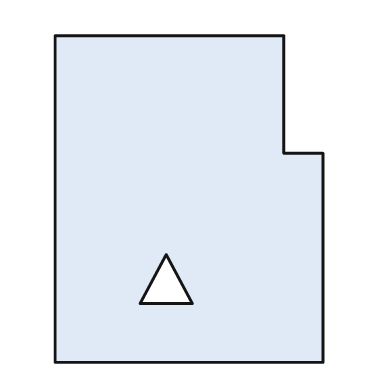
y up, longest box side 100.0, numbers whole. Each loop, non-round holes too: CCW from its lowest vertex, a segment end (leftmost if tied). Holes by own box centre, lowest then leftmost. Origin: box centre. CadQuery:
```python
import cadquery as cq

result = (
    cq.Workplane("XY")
    .moveTo(-41.0, -50.0)
    .lineTo(41.0, -50.0)
    .lineTo(41.0, 14.0)
    .lineTo(29.0, 14.0)
    .lineTo(29.0, 50.0)
    .lineTo(-41.0, 50.0)
    .close()
    .moveTo(-15.0, -32.0)
    .lineTo(1.0, -32.0)
    .lineTo(-7.0, -17.0)
    .close()
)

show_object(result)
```